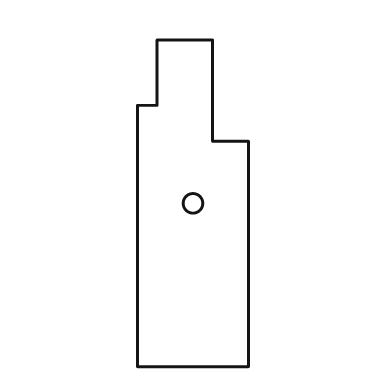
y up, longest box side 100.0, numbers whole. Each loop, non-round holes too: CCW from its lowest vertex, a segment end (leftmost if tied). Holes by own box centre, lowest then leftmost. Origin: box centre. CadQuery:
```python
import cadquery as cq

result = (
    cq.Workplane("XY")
    .moveTo(-17.0, -50.0)
    .lineTo(17.0, -50.0)
    .lineTo(17.0, 19.0)
    .lineTo(6.0, 19.0)
    .lineTo(6.0, 50.0)
    .lineTo(-11.0, 50.0)
    .lineTo(-11.0, 30.0)
    .lineTo(-17.0, 30.0)
    .close()
    .moveTo(0.0, 0.0)
    .circle(3.0)
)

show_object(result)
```